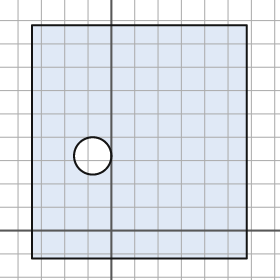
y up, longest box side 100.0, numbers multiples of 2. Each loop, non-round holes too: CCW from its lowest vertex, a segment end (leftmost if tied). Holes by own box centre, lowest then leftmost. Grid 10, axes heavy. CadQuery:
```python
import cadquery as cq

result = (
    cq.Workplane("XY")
    .moveTo(-34.0, -12.0)
    .lineTo(58.0, -12.0)
    .lineTo(58.0, 88.0)
    .lineTo(-34.0, 88.0)
    .close()
    .moveTo(-8.0, 32.0)
    .circle(8.0)
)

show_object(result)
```